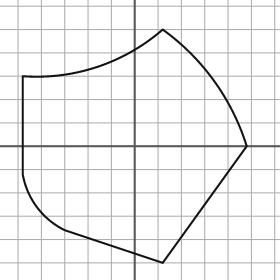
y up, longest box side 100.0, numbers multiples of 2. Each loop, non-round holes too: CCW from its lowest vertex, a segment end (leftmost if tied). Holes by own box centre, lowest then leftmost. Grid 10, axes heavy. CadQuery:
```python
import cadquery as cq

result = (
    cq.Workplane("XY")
    .moveTo(12.0, -50.0)
    .lineTo(48.0, 0.0)
    .threePointArc((34.0, 28.0), (12.0, 50.0))
    .threePointArc((-16.0, 34.0), (-48.0, 30.0))
    .lineTo(-48.0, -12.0)
    .threePointArc((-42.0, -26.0), (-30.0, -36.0))
    .close()
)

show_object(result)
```